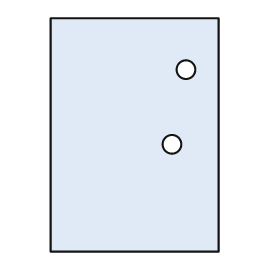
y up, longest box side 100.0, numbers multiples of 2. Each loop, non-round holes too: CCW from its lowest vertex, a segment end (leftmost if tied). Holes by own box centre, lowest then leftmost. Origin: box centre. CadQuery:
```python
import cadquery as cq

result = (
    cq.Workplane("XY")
    .moveTo(-36.0, -50.0)
    .lineTo(36.0, -50.0)
    .lineTo(36.0, 50.0)
    .lineTo(-36.0, 50.0)
    .close()
    .moveTo(16.0, -4.0)
    .circle(4.0)
    .moveTo(22.0, 28.0)
    .circle(4.0)
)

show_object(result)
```